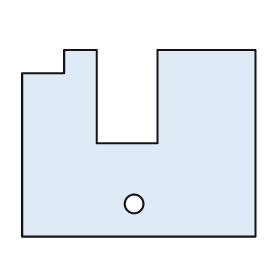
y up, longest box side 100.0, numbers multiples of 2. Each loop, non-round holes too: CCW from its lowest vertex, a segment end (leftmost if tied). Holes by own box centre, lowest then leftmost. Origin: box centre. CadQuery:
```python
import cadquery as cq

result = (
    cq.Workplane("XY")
    .moveTo(-50.0, -40.0)
    .lineTo(50.0, -40.0)
    .lineTo(50.0, 40.0)
    .lineTo(8.0, 40.0)
    .lineTo(8.0, 0.0)
    .lineTo(-18.0, 0.0)
    .lineTo(-18.0, 40.0)
    .lineTo(-32.0, 40.0)
    .lineTo(-32.0, 30.0)
    .lineTo(-50.0, 30.0)
    .close()
    .moveTo(-2.0, -26.0)
    .circle(4.0)
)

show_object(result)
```